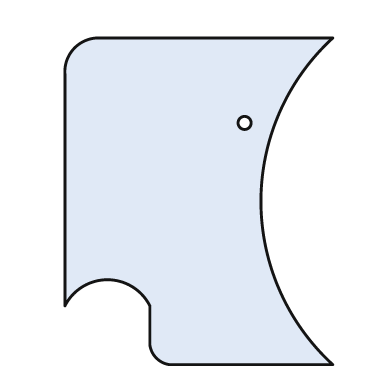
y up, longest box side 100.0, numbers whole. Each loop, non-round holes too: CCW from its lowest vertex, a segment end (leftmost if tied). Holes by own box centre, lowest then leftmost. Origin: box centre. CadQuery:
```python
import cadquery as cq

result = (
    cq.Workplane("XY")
    .moveTo(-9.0, -50.0)
    .lineTo(41.0, -50.0)
    .threePointArc((19.0, 0.0), (41.0, 50.0))
    .lineTo(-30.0, 50.0)
    .threePointArc((-38.0, 47.0), (-41.0, 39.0))
    .lineTo(-41.0, -32.0)
    .threePointArc((-28.0, -24.0), (-15.0, -32.0))
    .lineTo(-15.0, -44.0)
    .threePointArc((-13.0, -48.0), (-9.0, -50.0))
    .close()
    .moveTo(14.0, 24.0)
    .circle(2.0)
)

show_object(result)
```